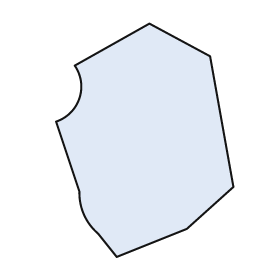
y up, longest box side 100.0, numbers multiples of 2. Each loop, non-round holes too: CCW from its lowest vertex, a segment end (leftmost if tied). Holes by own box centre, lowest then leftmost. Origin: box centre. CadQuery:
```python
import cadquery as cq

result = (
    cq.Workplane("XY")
    .moveTo(-12.0, -50.0)
    .lineTo(18.0, -38.0)
    .lineTo(38.0, -20.0)
    .lineTo(28.0, 36.0)
    .lineTo(2.0, 50.0)
    .lineTo(-30.0, 32.0)
    .threePointArc((-28.0, 18.0), (-38.0, 8.0))
    .lineTo(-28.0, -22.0)
    .threePointArc((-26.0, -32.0), (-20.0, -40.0))
    .close()
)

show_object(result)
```